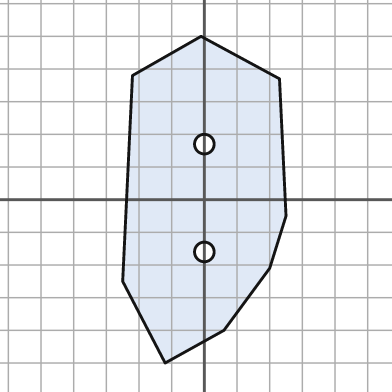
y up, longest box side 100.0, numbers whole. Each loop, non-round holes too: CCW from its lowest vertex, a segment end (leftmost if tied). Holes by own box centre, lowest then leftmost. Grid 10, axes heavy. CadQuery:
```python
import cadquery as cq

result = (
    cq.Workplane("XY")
    .moveTo(-12.0, -50.0)
    .lineTo(6.0, -40.0)
    .lineTo(20.0, -21.0)
    .lineTo(25.0, -5.0)
    .lineTo(23.0, 37.0)
    .lineTo(-1.0, 50.0)
    .lineTo(-22.0, 38.0)
    .lineTo(-25.0, -25.0)
    .close()
    .moveTo(0.0, -16.0)
    .circle(3.0)
    .moveTo(0.0, 17.0)
    .circle(3.0)
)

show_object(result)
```